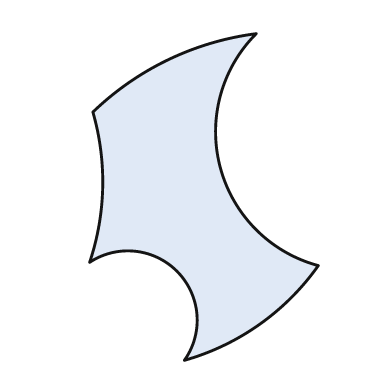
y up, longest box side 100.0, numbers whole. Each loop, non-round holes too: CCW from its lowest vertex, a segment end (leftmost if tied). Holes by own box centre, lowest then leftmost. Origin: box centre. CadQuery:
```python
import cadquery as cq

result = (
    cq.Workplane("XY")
    .moveTo(-6.0, -50.0)
    .threePointArc((17.0, -39.0), (35.0, -21.0))
    .threePointArc((5.0, 9.0), (16.0, 50.0))
    .threePointArc((-11.0, 42.0), (-34.0, 26.0))
    .threePointArc((-31.0, 3.0), (-35.0, -20.0))
    .threePointArc((-8.0, -23.0), (-6.0, -50.0))
    .close()
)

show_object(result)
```